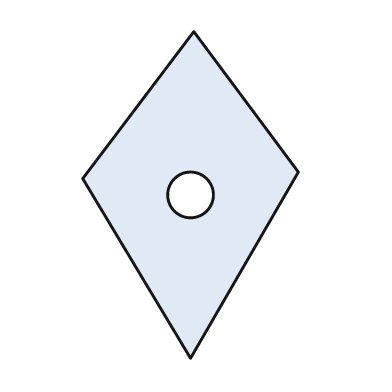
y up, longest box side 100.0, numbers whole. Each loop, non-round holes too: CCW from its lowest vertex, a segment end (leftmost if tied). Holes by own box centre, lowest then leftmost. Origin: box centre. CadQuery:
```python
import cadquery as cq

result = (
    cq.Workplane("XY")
    .moveTo(0.0, -50.0)
    .lineTo(33.0, 7.0)
    .lineTo(1.0, 50.0)
    .lineTo(-33.0, 5.0)
    .close()
    .moveTo(0.0, 0.0)
    .circle(7.0)
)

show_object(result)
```